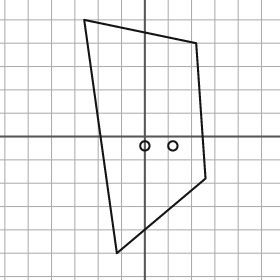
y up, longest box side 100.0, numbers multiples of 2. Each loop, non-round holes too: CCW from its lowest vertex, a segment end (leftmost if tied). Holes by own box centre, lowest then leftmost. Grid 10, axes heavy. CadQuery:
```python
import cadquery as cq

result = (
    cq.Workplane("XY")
    .moveTo(-12.0, -50.0)
    .lineTo(26.0, -18.0)
    .lineTo(22.0, 40.0)
    .lineTo(-26.0, 50.0)
    .close()
    .moveTo(0.0, -4.0)
    .circle(2.0)
    .moveTo(12.0, -4.0)
    .circle(2.0)
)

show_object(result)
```